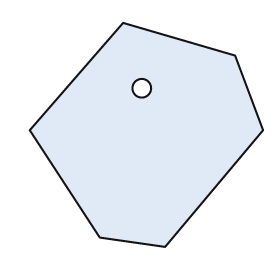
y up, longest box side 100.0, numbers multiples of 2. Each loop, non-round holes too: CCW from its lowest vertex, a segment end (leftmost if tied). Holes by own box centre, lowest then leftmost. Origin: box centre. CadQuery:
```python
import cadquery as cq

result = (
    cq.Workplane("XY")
    .moveTo(8.0, -48.0)
    .lineTo(50.0, 2.0)
    .lineTo(38.0, 34.0)
    .lineTo(-10.0, 48.0)
    .lineTo(-50.0, 2.0)
    .lineTo(-20.0, -44.0)
    .close()
    .moveTo(-2.0, 20.0)
    .circle(4.0)
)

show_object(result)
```